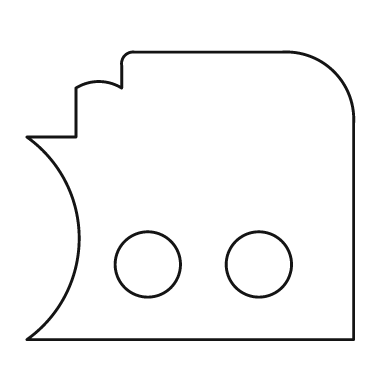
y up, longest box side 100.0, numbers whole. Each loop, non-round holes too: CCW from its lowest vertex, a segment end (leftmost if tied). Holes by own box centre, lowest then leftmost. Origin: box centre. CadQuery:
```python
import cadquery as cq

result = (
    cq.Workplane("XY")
    .moveTo(-50.0, -44.0)
    .lineTo(50.0, -44.0)
    .lineTo(50.0, 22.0)
    .threePointArc((44.0, 38.0), (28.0, 44.0))
    .lineTo(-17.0, 44.0)
    .threePointArc((-20.0, 43.0), (-21.0, 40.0))
    .lineTo(-21.0, 33.0)
    .threePointArc((-28.0, 35.0), (-35.0, 33.0))
    .lineTo(-35.0, 18.0)
    .lineTo(-50.0, 18.0)
    .threePointArc((-34.0, -13.0), (-50.0, -44.0))
    .close()
    .moveTo(-13.0, -21.0)
    .circle(10.0)
    .moveTo(21.0, -21.0)
    .circle(10.0)
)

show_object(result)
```